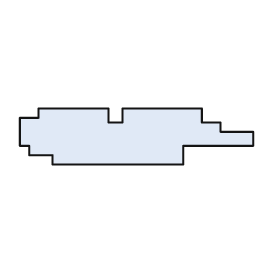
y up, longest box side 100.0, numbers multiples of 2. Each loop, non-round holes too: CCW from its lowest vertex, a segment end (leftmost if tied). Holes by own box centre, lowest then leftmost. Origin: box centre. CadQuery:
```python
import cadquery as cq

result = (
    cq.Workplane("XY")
    .moveTo(-36.0, -12.0)
    .lineTo(20.0, -12.0)
    .lineTo(20.0, -4.0)
    .lineTo(50.0, -4.0)
    .lineTo(50.0, 2.0)
    .lineTo(36.0, 2.0)
    .lineTo(36.0, 6.0)
    .lineTo(28.0, 6.0)
    .lineTo(28.0, 12.0)
    .lineTo(-6.0, 12.0)
    .lineTo(-6.0, 6.0)
    .lineTo(-12.0, 6.0)
    .lineTo(-12.0, 12.0)
    .lineTo(-42.0, 12.0)
    .lineTo(-42.0, 8.0)
    .lineTo(-50.0, 8.0)
    .lineTo(-50.0, -4.0)
    .lineTo(-46.0, -4.0)
    .lineTo(-46.0, -8.0)
    .lineTo(-36.0, -8.0)
    .close()
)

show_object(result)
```